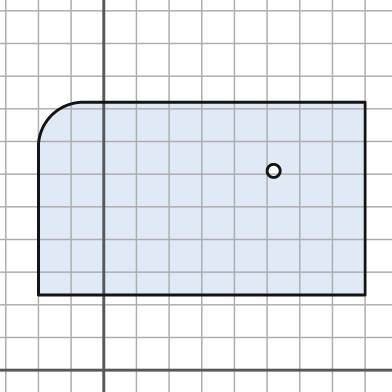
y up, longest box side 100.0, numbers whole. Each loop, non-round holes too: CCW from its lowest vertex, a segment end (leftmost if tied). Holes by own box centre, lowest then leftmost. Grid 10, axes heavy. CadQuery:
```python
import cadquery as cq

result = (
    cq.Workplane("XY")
    .moveTo(-20.0, 23.0)
    .lineTo(80.0, 23.0)
    .lineTo(80.0, 82.0)
    .lineTo(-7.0, 82.0)
    .threePointArc((-16.0, 78.0), (-20.0, 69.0))
    .close()
    .moveTo(52.0, 61.0)
    .circle(2.0)
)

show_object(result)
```